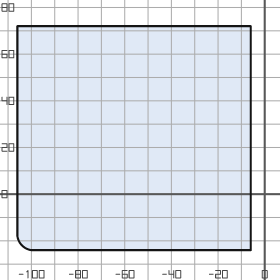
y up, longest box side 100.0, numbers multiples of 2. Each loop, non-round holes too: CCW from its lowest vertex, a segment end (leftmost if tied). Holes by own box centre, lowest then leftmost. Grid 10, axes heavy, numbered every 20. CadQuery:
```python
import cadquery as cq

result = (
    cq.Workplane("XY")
    .moveTo(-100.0, -24.0)
    .lineTo(-6.0, -24.0)
    .lineTo(-6.0, 72.0)
    .lineTo(-106.0, 72.0)
    .lineTo(-106.0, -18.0)
    .threePointArc((-104.0, -22.0), (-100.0, -24.0))
    .close()
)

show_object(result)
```